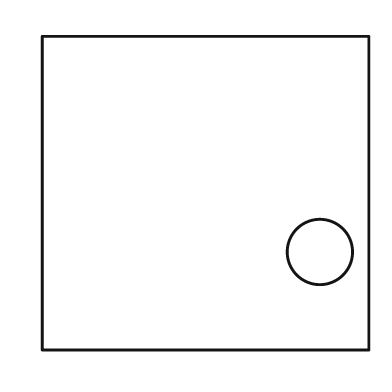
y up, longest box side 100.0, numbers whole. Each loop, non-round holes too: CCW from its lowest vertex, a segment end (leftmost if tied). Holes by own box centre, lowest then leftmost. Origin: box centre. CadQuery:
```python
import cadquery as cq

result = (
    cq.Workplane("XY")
    .moveTo(-50.0, -48.0)
    .lineTo(50.0, -48.0)
    .lineTo(50.0, 48.0)
    .lineTo(-50.0, 48.0)
    .close()
    .moveTo(35.0, -18.0)
    .circle(10.0)
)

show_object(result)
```